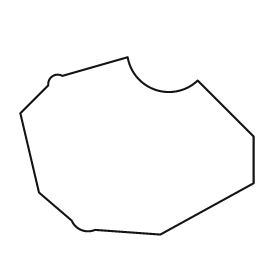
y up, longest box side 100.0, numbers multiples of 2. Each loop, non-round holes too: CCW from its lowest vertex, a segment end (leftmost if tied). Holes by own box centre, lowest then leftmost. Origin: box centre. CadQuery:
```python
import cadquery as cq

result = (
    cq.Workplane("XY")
    .moveTo(10.0, -38.0)
    .lineTo(50.0, -16.0)
    .lineTo(50.0, 4.0)
    .lineTo(26.0, 28.0)
    .threePointArc((8.0, 24.0), (-4.0, 38.0))
    .lineTo(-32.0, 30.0)
    .threePointArc((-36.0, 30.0), (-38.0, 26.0))
    .lineTo(-50.0, 14.0)
    .lineTo(-42.0, -20.0)
    .lineTo(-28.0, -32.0)
    .threePointArc((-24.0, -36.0), (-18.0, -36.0))
    .close()
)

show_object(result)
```